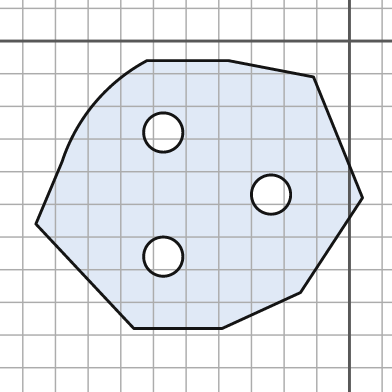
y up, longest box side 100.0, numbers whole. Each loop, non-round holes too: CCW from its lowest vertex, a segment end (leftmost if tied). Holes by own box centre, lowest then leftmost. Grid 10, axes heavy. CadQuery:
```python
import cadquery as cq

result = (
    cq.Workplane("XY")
    .moveTo(-66.0, -88.0)
    .lineTo(-39.0, -88.0)
    .lineTo(-15.0, -77.0)
    .lineTo(4.0, -48.0)
    .lineTo(-11.0, -11.0)
    .lineTo(-37.0, -6.0)
    .lineTo(-62.0, -6.0)
    .threePointArc((-78.0, -19.0), (-88.0, -37.0))
    .lineTo(-96.0, -56.0)
    .close()
    .moveTo(-57.0, -66.0)
    .circle(6.0)
    .moveTo(-24.0, -47.0)
    .circle(6.0)
    .moveTo(-57.0, -28.0)
    .circle(6.0)
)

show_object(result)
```